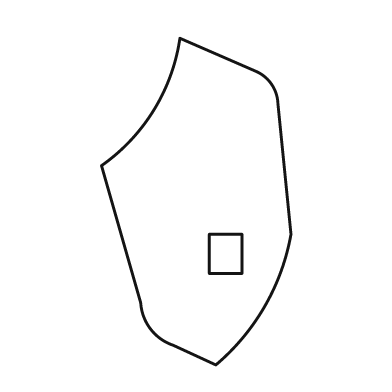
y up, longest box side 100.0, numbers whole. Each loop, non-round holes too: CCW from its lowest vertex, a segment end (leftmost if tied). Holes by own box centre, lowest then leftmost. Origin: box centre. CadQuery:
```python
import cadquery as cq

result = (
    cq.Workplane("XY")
    .moveTo(6.0, -50.0)
    .threePointArc((21.0, -32.0), (29.0, -10.0))
    .lineTo(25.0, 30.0)
    .threePointArc((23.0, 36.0), (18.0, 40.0))
    .lineTo(-5.0, 50.0)
    .threePointArc((-13.0, 28.0), (-29.0, 11.0))
    .lineTo(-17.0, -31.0)
    .threePointArc((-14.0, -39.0), (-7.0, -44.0))
    .close()
    .moveTo(4.0, -22.0)
    .lineTo(14.0, -22.0)
    .lineTo(14.0, -10.0)
    .lineTo(4.0, -10.0)
    .close()
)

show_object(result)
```